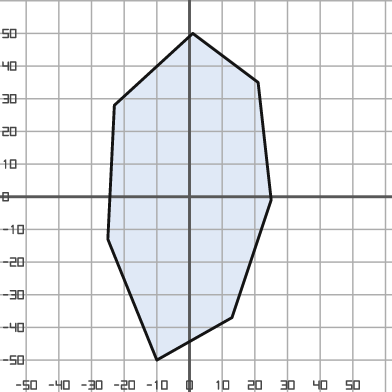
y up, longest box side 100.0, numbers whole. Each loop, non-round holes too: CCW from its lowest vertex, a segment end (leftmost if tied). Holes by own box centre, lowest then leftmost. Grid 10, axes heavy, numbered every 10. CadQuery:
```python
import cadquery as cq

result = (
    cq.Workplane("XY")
    .moveTo(-10.0, -50.0)
    .lineTo(13.0, -37.0)
    .lineTo(25.0, -1.0)
    .lineTo(21.0, 35.0)
    .lineTo(1.0, 50.0)
    .lineTo(-23.0, 28.0)
    .lineTo(-25.0, -13.0)
    .close()
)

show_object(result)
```